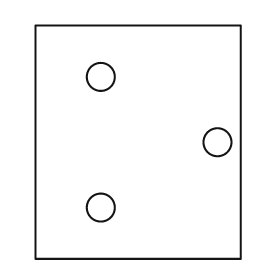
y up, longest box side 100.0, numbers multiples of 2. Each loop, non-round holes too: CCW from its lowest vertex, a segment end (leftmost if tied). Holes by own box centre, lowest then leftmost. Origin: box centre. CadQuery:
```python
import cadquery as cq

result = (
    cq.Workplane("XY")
    .moveTo(-44.0, -50.0)
    .lineTo(44.0, -50.0)
    .lineTo(44.0, 50.0)
    .lineTo(-44.0, 50.0)
    .close()
    .moveTo(-16.0, -28.0)
    .circle(6.0)
    .moveTo(34.0, 0.0)
    .circle(6.0)
    .moveTo(-16.0, 28.0)
    .circle(6.0)
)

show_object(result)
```